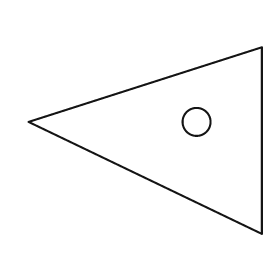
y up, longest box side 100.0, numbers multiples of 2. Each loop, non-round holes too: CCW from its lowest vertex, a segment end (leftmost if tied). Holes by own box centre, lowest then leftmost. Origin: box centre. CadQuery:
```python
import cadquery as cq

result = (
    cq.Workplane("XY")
    .moveTo(50.0, -40.0)
    .lineTo(50.0, 40.0)
    .lineTo(-50.0, 8.0)
    .close()
    .moveTo(22.0, 8.0)
    .circle(6.0)
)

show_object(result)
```